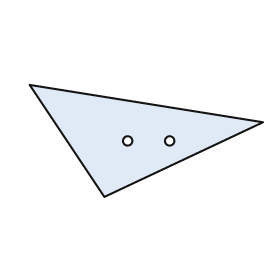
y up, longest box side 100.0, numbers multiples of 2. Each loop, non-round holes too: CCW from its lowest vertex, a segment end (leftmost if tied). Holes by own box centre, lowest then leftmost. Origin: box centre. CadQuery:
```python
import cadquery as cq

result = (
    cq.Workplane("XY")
    .moveTo(-18.0, -24.0)
    .lineTo(50.0, 8.0)
    .lineTo(-50.0, 24.0)
    .close()
    .moveTo(-8.0, 0.0)
    .circle(2.0)
    .moveTo(10.0, 0.0)
    .circle(2.0)
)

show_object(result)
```